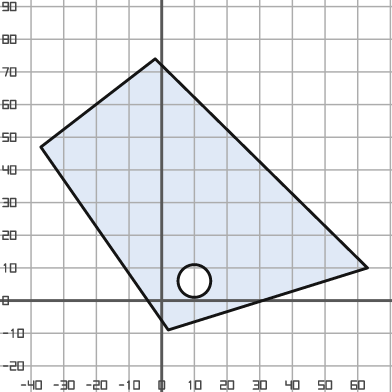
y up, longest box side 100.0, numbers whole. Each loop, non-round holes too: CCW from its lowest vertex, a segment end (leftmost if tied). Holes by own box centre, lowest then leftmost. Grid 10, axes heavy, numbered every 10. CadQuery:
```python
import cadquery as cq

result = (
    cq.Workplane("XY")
    .moveTo(2.0, -9.0)
    .lineTo(63.0, 10.0)
    .lineTo(-2.0, 74.0)
    .lineTo(-37.0, 47.0)
    .close()
    .moveTo(10.0, 6.0)
    .circle(5.0)
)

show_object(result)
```